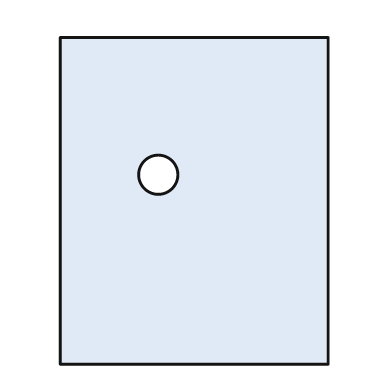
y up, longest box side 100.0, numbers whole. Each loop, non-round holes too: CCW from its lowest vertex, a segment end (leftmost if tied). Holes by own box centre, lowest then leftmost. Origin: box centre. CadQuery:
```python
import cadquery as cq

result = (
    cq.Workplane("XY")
    .moveTo(-41.0, -50.0)
    .lineTo(41.0, -50.0)
    .lineTo(41.0, 50.0)
    .lineTo(-41.0, 50.0)
    .close()
    .moveTo(-11.0, 8.0)
    .circle(6.0)
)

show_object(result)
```